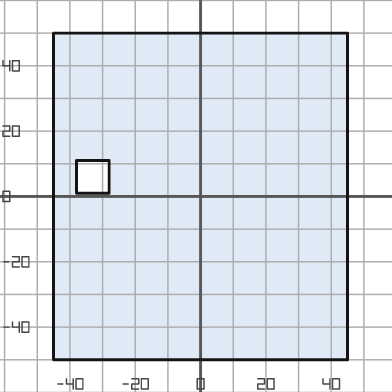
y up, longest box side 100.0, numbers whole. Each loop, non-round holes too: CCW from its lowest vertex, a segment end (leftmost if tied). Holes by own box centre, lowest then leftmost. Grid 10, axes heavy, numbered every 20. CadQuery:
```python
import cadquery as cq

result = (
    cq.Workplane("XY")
    .moveTo(-45.0, -50.0)
    .lineTo(45.0, -50.0)
    .lineTo(45.0, 50.0)
    .lineTo(-45.0, 50.0)
    .close()
    .moveTo(-38.0, 1.0)
    .lineTo(-28.0, 1.0)
    .lineTo(-28.0, 11.0)
    .lineTo(-38.0, 11.0)
    .close()
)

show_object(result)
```